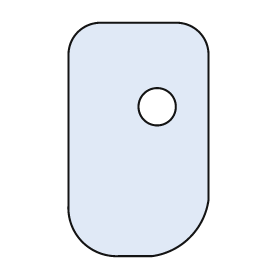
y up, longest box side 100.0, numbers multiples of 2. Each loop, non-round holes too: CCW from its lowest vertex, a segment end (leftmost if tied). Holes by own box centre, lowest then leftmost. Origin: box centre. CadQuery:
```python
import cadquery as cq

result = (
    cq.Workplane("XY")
    .moveTo(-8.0, -50.0)
    .lineTo(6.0, -50.0)
    .threePointArc((22.0, -42.0), (30.0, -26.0))
    .lineTo(30.0, 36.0)
    .threePointArc((26.0, 46.0), (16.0, 50.0))
    .lineTo(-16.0, 50.0)
    .threePointArc((-26.0, 46.0), (-30.0, 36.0))
    .lineTo(-30.0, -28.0)
    .threePointArc((-24.0, -44.0), (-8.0, -50.0))
    .close()
    .moveTo(8.0, 14.0)
    .circle(8.0)
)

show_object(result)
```